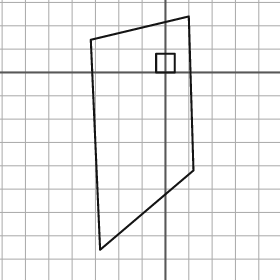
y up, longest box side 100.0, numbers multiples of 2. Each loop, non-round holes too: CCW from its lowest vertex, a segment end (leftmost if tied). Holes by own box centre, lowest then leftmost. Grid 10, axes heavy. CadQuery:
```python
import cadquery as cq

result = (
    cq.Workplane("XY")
    .moveTo(-28.0, -76.0)
    .lineTo(12.0, -42.0)
    .lineTo(10.0, 24.0)
    .lineTo(-32.0, 14.0)
    .close()
    .moveTo(-4.0, 0.0)
    .lineTo(4.0, 0.0)
    .lineTo(4.0, 8.0)
    .lineTo(-4.0, 8.0)
    .close()
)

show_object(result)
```